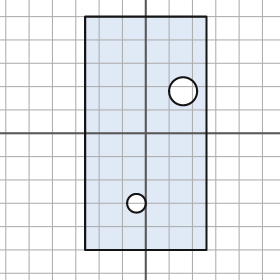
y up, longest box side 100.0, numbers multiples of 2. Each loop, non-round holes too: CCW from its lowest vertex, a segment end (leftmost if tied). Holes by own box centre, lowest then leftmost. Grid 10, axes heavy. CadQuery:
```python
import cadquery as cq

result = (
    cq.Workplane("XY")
    .moveTo(-26.0, -50.0)
    .lineTo(26.0, -50.0)
    .lineTo(26.0, 50.0)
    .lineTo(-26.0, 50.0)
    .close()
    .moveTo(-4.0, -30.0)
    .circle(4.0)
    .moveTo(16.0, 18.0)
    .circle(6.0)
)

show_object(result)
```